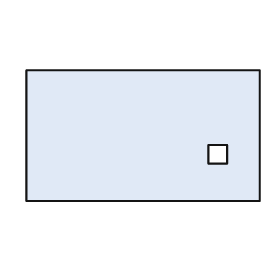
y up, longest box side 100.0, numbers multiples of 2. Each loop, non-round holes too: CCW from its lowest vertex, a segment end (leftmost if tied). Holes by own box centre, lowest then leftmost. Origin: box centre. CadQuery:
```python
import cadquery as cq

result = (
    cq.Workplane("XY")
    .moveTo(-50.0, -28.0)
    .lineTo(50.0, -28.0)
    .lineTo(50.0, 28.0)
    .lineTo(-50.0, 28.0)
    .close()
    .moveTo(28.0, -12.0)
    .lineTo(36.0, -12.0)
    .lineTo(36.0, -4.0)
    .lineTo(28.0, -4.0)
    .close()
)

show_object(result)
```